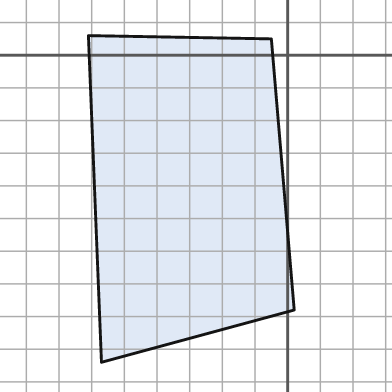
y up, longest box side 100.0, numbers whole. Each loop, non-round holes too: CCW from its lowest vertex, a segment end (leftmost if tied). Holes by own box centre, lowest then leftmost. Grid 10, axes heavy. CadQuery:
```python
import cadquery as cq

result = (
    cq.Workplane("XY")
    .moveTo(-57.0, -94.0)
    .lineTo(2.0, -78.0)
    .lineTo(-5.0, 5.0)
    .lineTo(-61.0, 6.0)
    .close()
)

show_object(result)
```